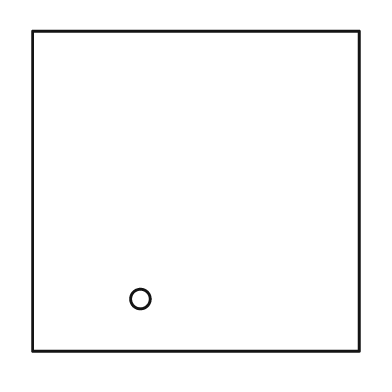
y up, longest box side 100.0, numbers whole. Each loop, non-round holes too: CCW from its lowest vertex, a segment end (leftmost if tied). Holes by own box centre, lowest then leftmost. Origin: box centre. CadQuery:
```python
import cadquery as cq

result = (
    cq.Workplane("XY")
    .moveTo(-50.0, -49.0)
    .lineTo(50.0, -49.0)
    .lineTo(50.0, 49.0)
    .lineTo(-50.0, 49.0)
    .close()
    .moveTo(-17.0, -33.0)
    .circle(3.0)
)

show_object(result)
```